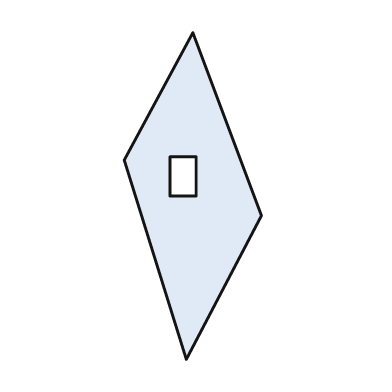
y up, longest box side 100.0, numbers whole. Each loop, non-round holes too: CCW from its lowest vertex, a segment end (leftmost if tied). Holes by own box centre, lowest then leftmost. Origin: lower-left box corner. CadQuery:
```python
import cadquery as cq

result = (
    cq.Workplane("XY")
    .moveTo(19.0, 0.0)
    .lineTo(42.0, 44.0)
    .lineTo(21.0, 100.0)
    .lineTo(0.0, 61.0)
    .close()
    .moveTo(14.0, 50.0)
    .lineTo(22.0, 50.0)
    .lineTo(22.0, 62.0)
    .lineTo(14.0, 62.0)
    .close()
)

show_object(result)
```